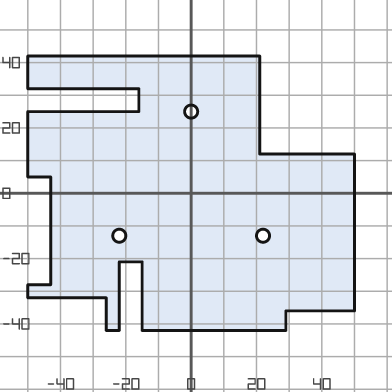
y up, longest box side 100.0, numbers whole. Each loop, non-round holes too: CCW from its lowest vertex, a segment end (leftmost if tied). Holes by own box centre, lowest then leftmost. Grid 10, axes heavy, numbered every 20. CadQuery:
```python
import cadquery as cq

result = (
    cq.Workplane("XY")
    .moveTo(-26.0, -42.0)
    .lineTo(-22.0, -42.0)
    .lineTo(-22.0, -21.0)
    .lineTo(-15.0, -21.0)
    .lineTo(-15.0, -42.0)
    .lineTo(29.0, -42.0)
    .lineTo(29.0, -36.0)
    .lineTo(50.0, -36.0)
    .lineTo(50.0, 12.0)
    .lineTo(21.0, 12.0)
    .lineTo(21.0, 42.0)
    .lineTo(-50.0, 42.0)
    .lineTo(-50.0, 32.0)
    .lineTo(-16.0, 32.0)
    .lineTo(-16.0, 25.0)
    .lineTo(-50.0, 25.0)
    .lineTo(-50.0, 5.0)
    .lineTo(-43.0, 5.0)
    .lineTo(-43.0, -28.0)
    .lineTo(-50.0, -28.0)
    .lineTo(-50.0, -32.0)
    .lineTo(-26.0, -32.0)
    .close()
    .moveTo(-22.0, -13.0)
    .circle(2.0)
    .moveTo(22.0, -13.0)
    .circle(2.0)
    .moveTo(0.0, 25.0)
    .circle(2.0)
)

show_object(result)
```